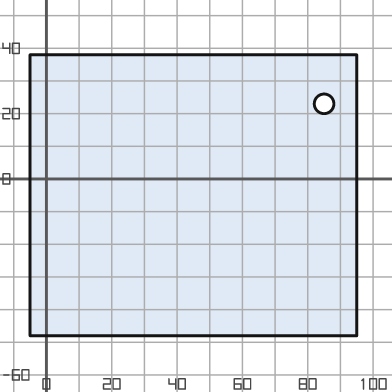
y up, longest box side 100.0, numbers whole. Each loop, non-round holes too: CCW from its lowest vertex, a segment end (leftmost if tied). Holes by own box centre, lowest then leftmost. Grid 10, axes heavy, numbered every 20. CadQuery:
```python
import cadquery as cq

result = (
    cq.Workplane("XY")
    .moveTo(-5.0, -48.0)
    .lineTo(95.0, -48.0)
    .lineTo(95.0, 38.0)
    .lineTo(-5.0, 38.0)
    .close()
    .moveTo(85.0, 23.0)
    .circle(3.0)
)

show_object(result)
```